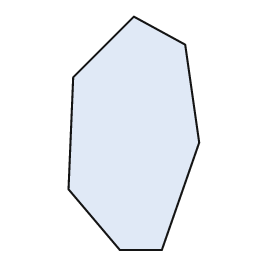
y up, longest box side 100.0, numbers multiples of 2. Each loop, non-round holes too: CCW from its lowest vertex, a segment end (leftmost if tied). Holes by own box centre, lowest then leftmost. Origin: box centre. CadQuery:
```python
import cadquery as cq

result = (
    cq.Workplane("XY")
    .moveTo(-6.0, -50.0)
    .lineTo(12.0, -50.0)
    .lineTo(28.0, -4.0)
    .lineTo(22.0, 38.0)
    .lineTo(0.0, 50.0)
    .lineTo(-26.0, 24.0)
    .lineTo(-28.0, -24.0)
    .close()
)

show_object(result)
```